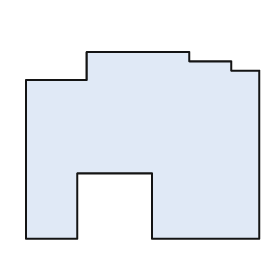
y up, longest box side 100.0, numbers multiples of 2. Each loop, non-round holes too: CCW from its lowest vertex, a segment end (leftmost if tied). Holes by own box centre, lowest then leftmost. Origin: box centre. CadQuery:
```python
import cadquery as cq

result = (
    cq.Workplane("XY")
    .moveTo(-50.0, -40.0)
    .lineTo(-28.0, -40.0)
    .lineTo(-28.0, -12.0)
    .lineTo(4.0, -12.0)
    .lineTo(4.0, -40.0)
    .lineTo(50.0, -40.0)
    .lineTo(50.0, 32.0)
    .lineTo(38.0, 32.0)
    .lineTo(38.0, 36.0)
    .lineTo(20.0, 36.0)
    .lineTo(20.0, 40.0)
    .lineTo(-24.0, 40.0)
    .lineTo(-24.0, 28.0)
    .lineTo(-50.0, 28.0)
    .close()
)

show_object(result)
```